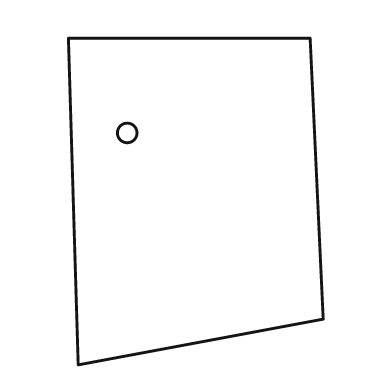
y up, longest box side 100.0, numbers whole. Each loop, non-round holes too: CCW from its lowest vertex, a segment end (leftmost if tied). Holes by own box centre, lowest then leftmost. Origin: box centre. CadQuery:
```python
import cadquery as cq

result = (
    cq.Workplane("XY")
    .moveTo(-36.0, -50.0)
    .lineTo(39.0, -36.0)
    .lineTo(35.0, 50.0)
    .lineTo(-39.0, 50.0)
    .close()
    .moveTo(-21.0, 21.0)
    .circle(3.0)
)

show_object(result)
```